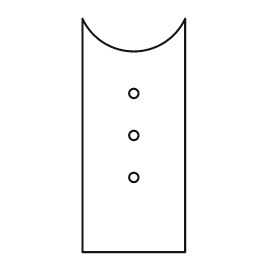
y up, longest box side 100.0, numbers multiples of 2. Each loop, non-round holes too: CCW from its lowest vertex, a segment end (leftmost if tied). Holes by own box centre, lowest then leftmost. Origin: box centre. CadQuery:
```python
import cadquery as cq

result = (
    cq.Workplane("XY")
    .moveTo(-22.0, -50.0)
    .lineTo(22.0, -50.0)
    .lineTo(22.0, 50.0)
    .threePointArc((0.0, 36.0), (-22.0, 50.0))
    .close()
    .moveTo(0.0, -18.0)
    .circle(2.0)
    .moveTo(0.0, 0.0)
    .circle(2.0)
    .moveTo(0.0, 18.0)
    .circle(2.0)
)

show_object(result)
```